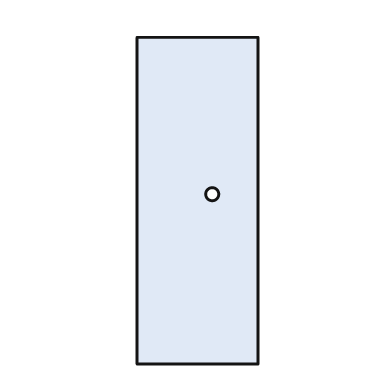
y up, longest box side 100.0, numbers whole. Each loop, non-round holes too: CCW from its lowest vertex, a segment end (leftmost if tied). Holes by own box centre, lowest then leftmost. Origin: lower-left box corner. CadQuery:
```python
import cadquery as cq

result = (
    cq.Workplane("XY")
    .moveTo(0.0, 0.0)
    .lineTo(37.0, 0.0)
    .lineTo(37.0, 100.0)
    .lineTo(0.0, 100.0)
    .close()
    .moveTo(23.0, 52.0)
    .circle(2.0)
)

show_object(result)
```